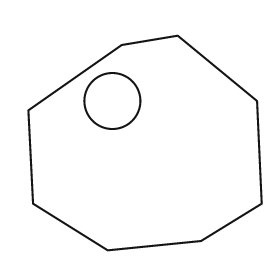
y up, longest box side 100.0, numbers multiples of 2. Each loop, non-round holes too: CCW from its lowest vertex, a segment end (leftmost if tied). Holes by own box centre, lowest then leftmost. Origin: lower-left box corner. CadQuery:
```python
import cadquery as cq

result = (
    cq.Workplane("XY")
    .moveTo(34.0, 0.0)
    .lineTo(74.0, 4.0)
    .lineTo(100.0, 20.0)
    .lineTo(98.0, 64.0)
    .lineTo(64.0, 92.0)
    .lineTo(40.0, 88.0)
    .lineTo(0.0, 60.0)
    .lineTo(2.0, 20.0)
    .close()
    .moveTo(36.0, 64.0)
    .circle(12.0)
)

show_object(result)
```